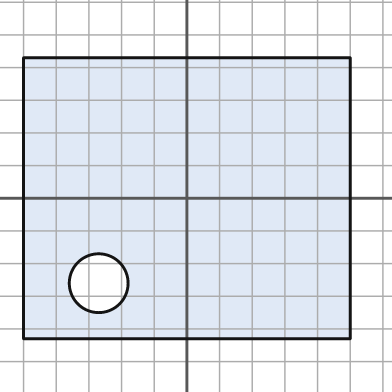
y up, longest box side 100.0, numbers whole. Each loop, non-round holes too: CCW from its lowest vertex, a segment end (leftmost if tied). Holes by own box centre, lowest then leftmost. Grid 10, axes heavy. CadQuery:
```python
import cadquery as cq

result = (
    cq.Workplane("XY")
    .moveTo(-50.0, -43.0)
    .lineTo(50.0, -43.0)
    .lineTo(50.0, 43.0)
    .lineTo(-50.0, 43.0)
    .close()
    .moveTo(-27.0, -26.0)
    .circle(9.0)
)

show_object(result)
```